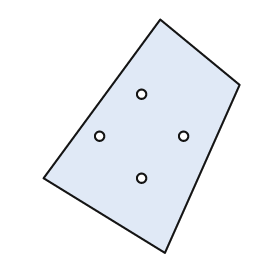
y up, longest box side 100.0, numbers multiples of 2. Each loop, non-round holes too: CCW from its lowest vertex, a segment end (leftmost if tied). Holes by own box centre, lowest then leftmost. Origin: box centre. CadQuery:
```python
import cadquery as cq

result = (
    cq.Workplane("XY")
    .moveTo(10.0, -50.0)
    .lineTo(42.0, 22.0)
    .lineTo(8.0, 50.0)
    .lineTo(-42.0, -18.0)
    .close()
    .moveTo(0.0, -18.0)
    .circle(2.0)
    .moveTo(-18.0, 0.0)
    .circle(2.0)
    .moveTo(18.0, 0.0)
    .circle(2.0)
    .moveTo(0.0, 18.0)
    .circle(2.0)
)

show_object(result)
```